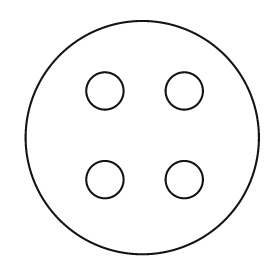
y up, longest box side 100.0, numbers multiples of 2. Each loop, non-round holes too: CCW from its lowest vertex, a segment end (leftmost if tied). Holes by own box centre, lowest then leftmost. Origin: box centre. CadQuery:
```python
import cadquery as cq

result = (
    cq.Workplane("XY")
    .moveTo(0.0, 0.0)
    .circle(50.0)
    .moveTo(-16.0, -18.0)
    .circle(8.0)
    .moveTo(18.0, -18.0)
    .circle(8.0)
    .moveTo(-16.0, 20.0)
    .circle(8.0)
    .moveTo(18.0, 20.0)
    .circle(8.0)
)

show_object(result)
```